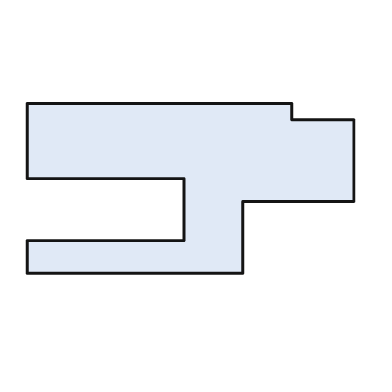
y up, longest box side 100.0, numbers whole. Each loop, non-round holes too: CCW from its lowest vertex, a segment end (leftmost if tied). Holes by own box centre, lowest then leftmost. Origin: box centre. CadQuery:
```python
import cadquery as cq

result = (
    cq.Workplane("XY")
    .moveTo(-50.0, -26.0)
    .lineTo(16.0, -26.0)
    .lineTo(16.0, -4.0)
    .lineTo(50.0, -4.0)
    .lineTo(50.0, 21.0)
    .lineTo(31.0, 21.0)
    .lineTo(31.0, 26.0)
    .lineTo(-50.0, 26.0)
    .lineTo(-50.0, 3.0)
    .lineTo(-2.0, 3.0)
    .lineTo(-2.0, -16.0)
    .lineTo(-50.0, -16.0)
    .close()
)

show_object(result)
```